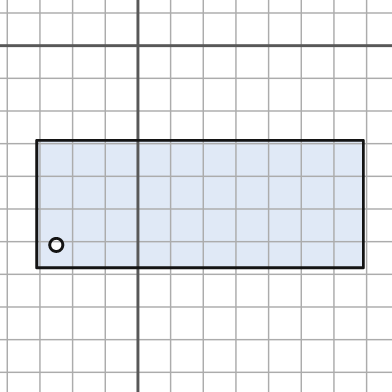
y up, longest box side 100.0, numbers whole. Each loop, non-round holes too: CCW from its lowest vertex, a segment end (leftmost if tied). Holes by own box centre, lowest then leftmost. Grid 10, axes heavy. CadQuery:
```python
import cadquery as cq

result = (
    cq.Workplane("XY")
    .moveTo(-31.0, -68.0)
    .lineTo(69.0, -68.0)
    .lineTo(69.0, -29.0)
    .lineTo(-31.0, -29.0)
    .close()
    .moveTo(-25.0, -61.0)
    .circle(2.0)
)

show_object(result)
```